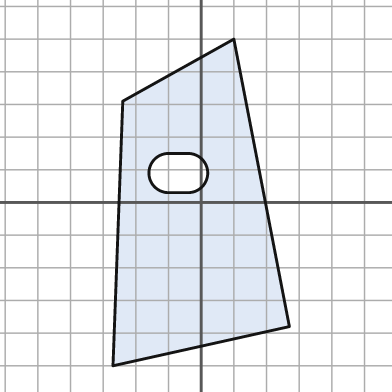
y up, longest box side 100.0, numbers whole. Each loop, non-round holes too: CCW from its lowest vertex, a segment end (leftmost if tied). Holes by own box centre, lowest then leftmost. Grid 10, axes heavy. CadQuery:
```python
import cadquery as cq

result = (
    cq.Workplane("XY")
    .moveTo(-27.0, -50.0)
    .lineTo(27.0, -38.0)
    .lineTo(10.0, 50.0)
    .lineTo(-24.0, 31.0)
    .close()
    .moveTo(-10.0, 3.0)
    .lineTo(-4.0, 3.0)
    .threePointArc((2.0, 9.0), (-4.0, 15.0))
    .lineTo(-10.0, 15.0)
    .threePointArc((-16.0, 9.0), (-10.0, 3.0))
    .close()
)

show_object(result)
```